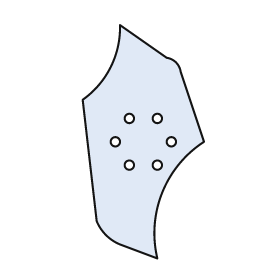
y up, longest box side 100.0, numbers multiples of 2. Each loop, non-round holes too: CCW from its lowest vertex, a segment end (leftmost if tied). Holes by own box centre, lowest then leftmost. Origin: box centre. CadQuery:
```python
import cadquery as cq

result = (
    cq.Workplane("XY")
    .moveTo(6.0, -50.0)
    .threePointArc((8.0, -22.0), (26.0, 0.0))
    .lineTo(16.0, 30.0)
    .threePointArc((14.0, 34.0), (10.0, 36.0))
    .lineTo(-10.0, 50.0)
    .threePointArc((-14.0, 32.0), (-26.0, 18.0))
    .lineTo(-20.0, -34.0)
    .threePointArc((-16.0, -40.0), (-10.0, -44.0))
    .close()
    .moveTo(-6.0, -10.0)
    .circle(2.0)
    .moveTo(6.0, -10.0)
    .circle(2.0)
    .moveTo(-12.0, 0.0)
    .circle(2.0)
    .moveTo(12.0, 0.0)
    .circle(2.0)
    .moveTo(-6.0, 10.0)
    .circle(2.0)
    .moveTo(6.0, 10.0)
    .circle(2.0)
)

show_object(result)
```